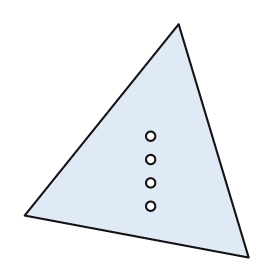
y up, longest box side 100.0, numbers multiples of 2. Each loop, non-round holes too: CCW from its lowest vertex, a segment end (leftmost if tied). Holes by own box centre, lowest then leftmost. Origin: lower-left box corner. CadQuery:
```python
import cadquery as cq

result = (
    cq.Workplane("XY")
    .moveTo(96.0, 0.0)
    .lineTo(66.0, 100.0)
    .lineTo(0.0, 18.0)
    .close()
    .moveTo(54.0, 22.0)
    .circle(2.0)
    .moveTo(54.0, 32.0)
    .circle(2.0)
    .moveTo(54.0, 42.0)
    .circle(2.0)
    .moveTo(54.0, 52.0)
    .circle(2.0)
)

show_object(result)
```